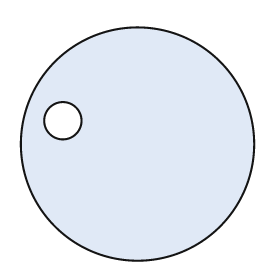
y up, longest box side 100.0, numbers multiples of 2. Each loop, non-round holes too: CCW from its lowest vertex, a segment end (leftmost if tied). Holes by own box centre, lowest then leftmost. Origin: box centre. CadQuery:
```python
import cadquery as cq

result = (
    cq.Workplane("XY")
    .moveTo(0.0, 0.0)
    .circle(50.0)
    .moveTo(-32.0, 10.0)
    .circle(8.0)
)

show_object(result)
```